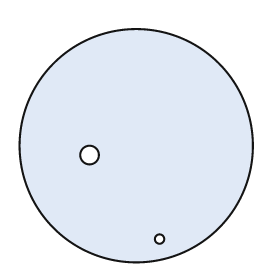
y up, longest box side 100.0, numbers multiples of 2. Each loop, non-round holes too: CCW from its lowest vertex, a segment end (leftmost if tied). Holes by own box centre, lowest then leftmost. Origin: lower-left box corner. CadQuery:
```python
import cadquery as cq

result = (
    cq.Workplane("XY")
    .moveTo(50.0, 50.0)
    .circle(50.0)
    .moveTo(60.0, 10.0)
    .circle(2.0)
    .moveTo(30.0, 46.0)
    .circle(4.0)
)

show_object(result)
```